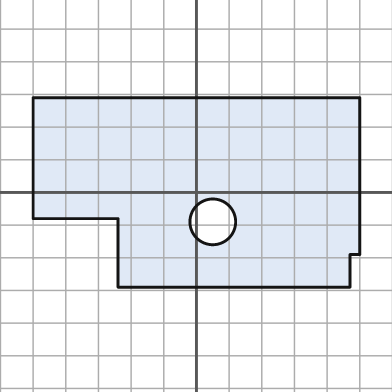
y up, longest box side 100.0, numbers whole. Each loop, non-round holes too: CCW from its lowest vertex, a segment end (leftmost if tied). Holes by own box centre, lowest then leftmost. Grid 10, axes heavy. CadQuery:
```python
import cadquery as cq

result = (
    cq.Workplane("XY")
    .moveTo(-24.0, -29.0)
    .lineTo(47.0, -29.0)
    .lineTo(47.0, -19.0)
    .lineTo(50.0, -19.0)
    .lineTo(50.0, 29.0)
    .lineTo(-50.0, 29.0)
    .lineTo(-50.0, -8.0)
    .lineTo(-24.0, -8.0)
    .close()
    .moveTo(5.0, -9.0)
    .circle(7.0)
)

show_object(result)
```